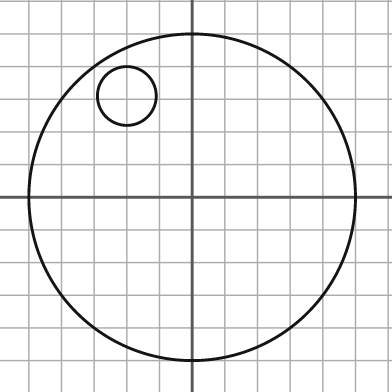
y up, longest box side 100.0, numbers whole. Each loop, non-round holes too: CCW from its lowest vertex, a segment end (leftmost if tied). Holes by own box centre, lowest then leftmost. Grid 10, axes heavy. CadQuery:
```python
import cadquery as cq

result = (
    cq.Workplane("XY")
    .moveTo(0.0, 0.0)
    .circle(50.0)
    .moveTo(-20.0, 31.0)
    .circle(9.0)
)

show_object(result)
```